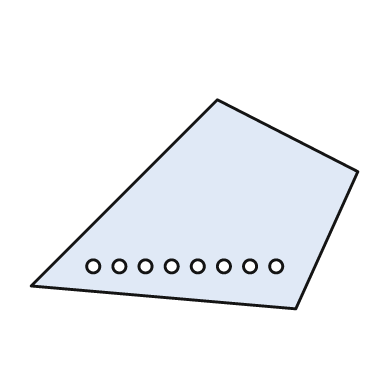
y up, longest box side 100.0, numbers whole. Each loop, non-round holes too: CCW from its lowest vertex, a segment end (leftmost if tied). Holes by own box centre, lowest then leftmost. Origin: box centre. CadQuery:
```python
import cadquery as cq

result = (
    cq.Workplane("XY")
    .moveTo(31.0, -32.0)
    .lineTo(50.0, 10.0)
    .lineTo(7.0, 32.0)
    .lineTo(-50.0, -25.0)
    .close()
    .moveTo(-31.0, -19.0)
    .circle(2.0)
    .moveTo(-23.0, -19.0)
    .circle(2.0)
    .moveTo(-15.0, -19.0)
    .circle(2.0)
    .moveTo(-7.0, -19.0)
    .circle(2.0)
    .moveTo(1.0, -19.0)
    .circle(2.0)
    .moveTo(9.0, -19.0)
    .circle(2.0)
    .moveTo(17.0, -19.0)
    .circle(2.0)
    .moveTo(25.0, -19.0)
    .circle(2.0)
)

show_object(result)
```